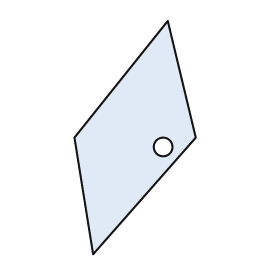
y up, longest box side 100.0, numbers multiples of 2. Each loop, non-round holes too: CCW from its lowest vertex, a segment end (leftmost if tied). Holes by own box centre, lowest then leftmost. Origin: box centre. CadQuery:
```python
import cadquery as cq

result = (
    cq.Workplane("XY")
    .moveTo(-18.0, -50.0)
    .lineTo(26.0, 0.0)
    .lineTo(14.0, 50.0)
    .lineTo(-26.0, 0.0)
    .close()
    .moveTo(12.0, -4.0)
    .circle(4.0)
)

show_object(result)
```